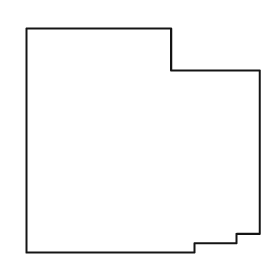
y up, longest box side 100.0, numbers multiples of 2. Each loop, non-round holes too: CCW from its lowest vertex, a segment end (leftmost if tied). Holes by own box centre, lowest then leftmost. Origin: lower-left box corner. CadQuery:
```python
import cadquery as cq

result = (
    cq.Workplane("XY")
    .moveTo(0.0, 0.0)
    .lineTo(72.0, 0.0)
    .lineTo(72.0, 4.0)
    .lineTo(90.0, 4.0)
    .lineTo(90.0, 8.0)
    .lineTo(100.0, 8.0)
    .lineTo(100.0, 78.0)
    .lineTo(62.0, 78.0)
    .lineTo(62.0, 96.0)
    .lineTo(0.0, 96.0)
    .close()
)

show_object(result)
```